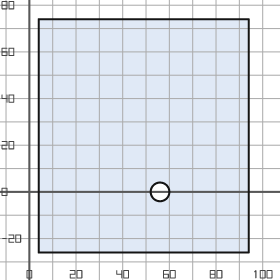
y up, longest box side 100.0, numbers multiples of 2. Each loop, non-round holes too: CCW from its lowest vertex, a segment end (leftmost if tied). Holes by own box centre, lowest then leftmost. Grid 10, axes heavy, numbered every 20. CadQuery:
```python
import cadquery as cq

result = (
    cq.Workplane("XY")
    .moveTo(4.0, -26.0)
    .lineTo(94.0, -26.0)
    .lineTo(94.0, 74.0)
    .lineTo(4.0, 74.0)
    .close()
    .moveTo(56.0, 0.0)
    .circle(4.0)
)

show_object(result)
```